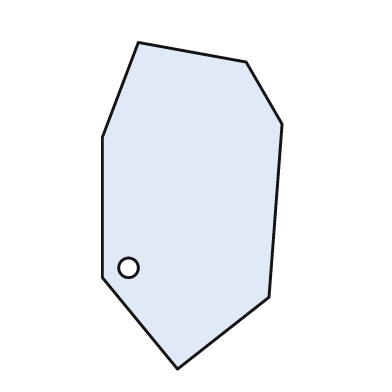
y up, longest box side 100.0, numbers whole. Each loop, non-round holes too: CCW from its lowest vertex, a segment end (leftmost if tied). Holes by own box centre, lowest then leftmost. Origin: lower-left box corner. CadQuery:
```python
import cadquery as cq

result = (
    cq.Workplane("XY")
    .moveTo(23.0, 0.0)
    .lineTo(51.0, 22.0)
    .lineTo(55.0, 75.0)
    .lineTo(44.0, 94.0)
    .lineTo(11.0, 100.0)
    .lineTo(0.0, 71.0)
    .lineTo(0.0, 28.0)
    .close()
    .moveTo(8.0, 31.0)
    .circle(3.0)
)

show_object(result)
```